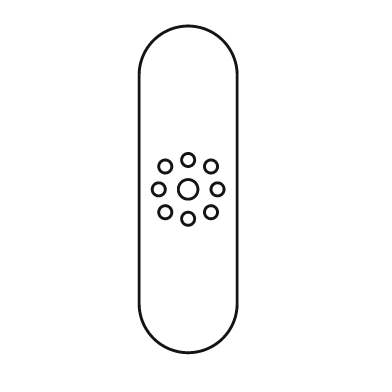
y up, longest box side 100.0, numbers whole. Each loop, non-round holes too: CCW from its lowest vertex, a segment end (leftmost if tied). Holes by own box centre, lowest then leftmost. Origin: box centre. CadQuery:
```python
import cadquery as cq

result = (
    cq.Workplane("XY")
    .moveTo(-15.0, -35.0)
    .threePointArc((0.0, -50.0), (15.0, -35.0))
    .lineTo(15.0, 35.0)
    .threePointArc((0.0, 50.0), (-15.0, 35.0))
    .close()
    .moveTo(0.0, -9.0)
    .circle(2.0)
    .moveTo(-7.0, -7.0)
    .circle(2.0)
    .moveTo(7.0, -7.0)
    .circle(2.0)
    .moveTo(-9.0, 0.0)
    .circle(2.0)
    .moveTo(0.0, 0.0)
    .circle(3.0)
    .moveTo(9.0, 0.0)
    .circle(2.0)
    .moveTo(-7.0, 7.0)
    .circle(2.0)
    .moveTo(7.0, 7.0)
    .circle(2.0)
    .moveTo(0.0, 9.0)
    .circle(2.0)
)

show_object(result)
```